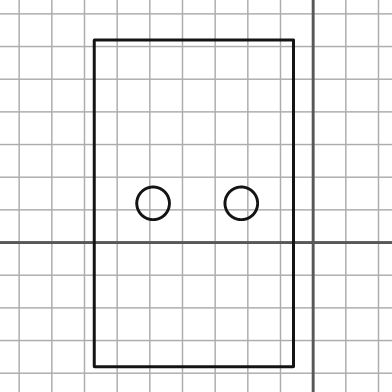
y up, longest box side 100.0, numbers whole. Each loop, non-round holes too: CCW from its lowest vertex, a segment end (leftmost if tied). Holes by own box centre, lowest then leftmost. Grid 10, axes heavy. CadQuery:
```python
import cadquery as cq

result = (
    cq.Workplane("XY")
    .moveTo(-67.0, -38.0)
    .lineTo(-6.0, -38.0)
    .lineTo(-6.0, 62.0)
    .lineTo(-67.0, 62.0)
    .close()
    .moveTo(-49.0, 12.0)
    .circle(5.0)
    .moveTo(-22.0, 12.0)
    .circle(5.0)
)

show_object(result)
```